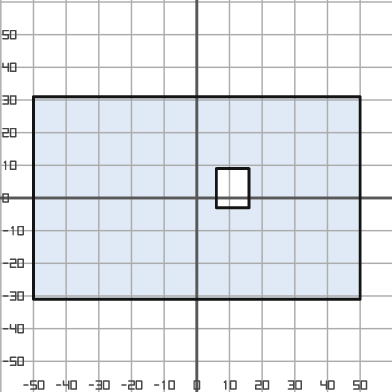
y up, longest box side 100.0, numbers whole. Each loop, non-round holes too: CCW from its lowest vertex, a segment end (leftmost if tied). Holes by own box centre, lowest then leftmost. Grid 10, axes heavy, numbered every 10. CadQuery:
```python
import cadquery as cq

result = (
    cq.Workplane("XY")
    .moveTo(-50.0, -31.0)
    .lineTo(50.0, -31.0)
    .lineTo(50.0, 31.0)
    .lineTo(-50.0, 31.0)
    .close()
    .moveTo(6.0, -3.0)
    .lineTo(16.0, -3.0)
    .lineTo(16.0, 9.0)
    .lineTo(6.0, 9.0)
    .close()
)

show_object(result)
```